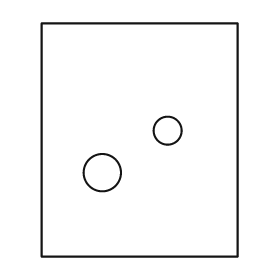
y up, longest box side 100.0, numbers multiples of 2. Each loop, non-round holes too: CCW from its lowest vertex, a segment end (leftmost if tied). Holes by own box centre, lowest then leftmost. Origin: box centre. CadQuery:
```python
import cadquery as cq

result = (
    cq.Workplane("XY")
    .moveTo(-42.0, -50.0)
    .lineTo(42.0, -50.0)
    .lineTo(42.0, 50.0)
    .lineTo(-42.0, 50.0)
    .close()
    .moveTo(-16.0, -14.0)
    .circle(8.0)
    .moveTo(12.0, 4.0)
    .circle(6.0)
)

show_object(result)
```